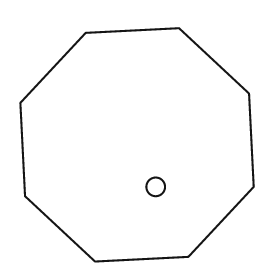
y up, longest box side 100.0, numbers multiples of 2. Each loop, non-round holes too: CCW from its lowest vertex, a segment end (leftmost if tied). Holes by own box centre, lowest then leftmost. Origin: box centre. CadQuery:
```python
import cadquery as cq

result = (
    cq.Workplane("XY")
    .moveTo(-18.0, -50.0)
    .lineTo(22.0, -48.0)
    .lineTo(50.0, -18.0)
    .lineTo(48.0, 22.0)
    .lineTo(18.0, 50.0)
    .lineTo(-22.0, 48.0)
    .lineTo(-50.0, 18.0)
    .lineTo(-48.0, -22.0)
    .close()
    .moveTo(8.0, -18.0)
    .circle(4.0)
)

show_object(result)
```